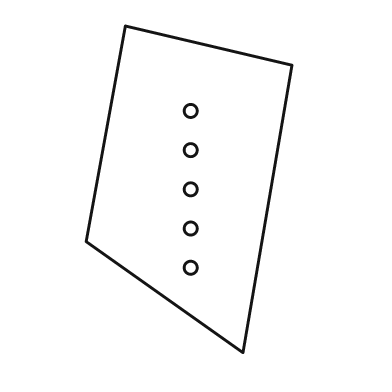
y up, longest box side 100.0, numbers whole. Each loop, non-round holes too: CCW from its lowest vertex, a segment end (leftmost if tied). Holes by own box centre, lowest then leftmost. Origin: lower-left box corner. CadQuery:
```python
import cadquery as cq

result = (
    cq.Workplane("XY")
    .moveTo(48.0, 0.0)
    .lineTo(63.0, 88.0)
    .lineTo(12.0, 100.0)
    .lineTo(0.0, 34.0)
    .close()
    .moveTo(32.0, 26.0)
    .circle(2.0)
    .moveTo(32.0, 38.0)
    .circle(2.0)
    .moveTo(32.0, 50.0)
    .circle(2.0)
    .moveTo(32.0, 62.0)
    .circle(2.0)
    .moveTo(32.0, 74.0)
    .circle(2.0)
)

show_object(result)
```